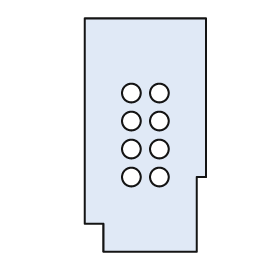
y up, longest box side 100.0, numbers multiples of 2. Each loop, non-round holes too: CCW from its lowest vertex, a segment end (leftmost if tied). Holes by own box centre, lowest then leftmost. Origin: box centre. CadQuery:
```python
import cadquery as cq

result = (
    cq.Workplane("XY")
    .moveTo(-18.0, -50.0)
    .lineTo(22.0, -50.0)
    .lineTo(22.0, -18.0)
    .lineTo(26.0, -18.0)
    .lineTo(26.0, 50.0)
    .lineTo(-26.0, 50.0)
    .lineTo(-26.0, -38.0)
    .lineTo(-18.0, -38.0)
    .close()
    .moveTo(-6.0, -18.0)
    .circle(4.0)
    .moveTo(6.0, -18.0)
    .circle(4.0)
    .moveTo(-6.0, -6.0)
    .circle(4.0)
    .moveTo(6.0, -6.0)
    .circle(4.0)
    .moveTo(-6.0, 6.0)
    .circle(4.0)
    .moveTo(6.0, 6.0)
    .circle(4.0)
    .moveTo(-6.0, 18.0)
    .circle(4.0)
    .moveTo(6.0, 18.0)
    .circle(4.0)
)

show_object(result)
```